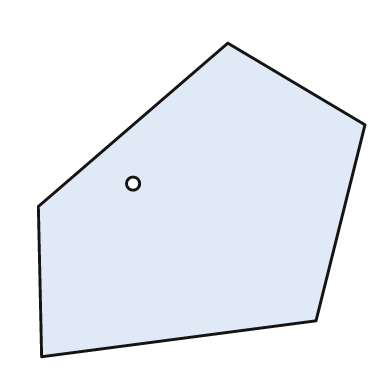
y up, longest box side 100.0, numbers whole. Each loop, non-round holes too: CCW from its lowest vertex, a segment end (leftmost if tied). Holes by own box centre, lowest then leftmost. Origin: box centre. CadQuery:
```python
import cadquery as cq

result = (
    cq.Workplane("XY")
    .moveTo(-49.0, -48.0)
    .lineTo(35.0, -37.0)
    .lineTo(50.0, 23.0)
    .lineTo(8.0, 48.0)
    .lineTo(-50.0, -2.0)
    .close()
    .moveTo(-21.0, 5.0)
    .circle(2.0)
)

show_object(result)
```